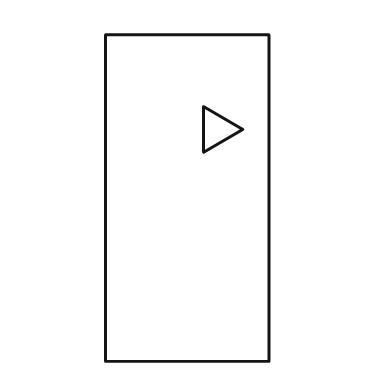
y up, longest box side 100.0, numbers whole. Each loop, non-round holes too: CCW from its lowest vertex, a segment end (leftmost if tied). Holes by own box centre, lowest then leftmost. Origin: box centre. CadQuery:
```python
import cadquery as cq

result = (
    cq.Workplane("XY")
    .moveTo(-25.0, -50.0)
    .lineTo(25.0, -50.0)
    .lineTo(25.0, 50.0)
    .lineTo(-25.0, 50.0)
    .close()
    .moveTo(5.0, 14.0)
    .lineTo(17.0, 21.0)
    .lineTo(5.0, 28.0)
    .close()
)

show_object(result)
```